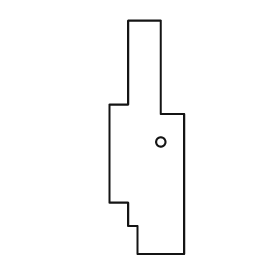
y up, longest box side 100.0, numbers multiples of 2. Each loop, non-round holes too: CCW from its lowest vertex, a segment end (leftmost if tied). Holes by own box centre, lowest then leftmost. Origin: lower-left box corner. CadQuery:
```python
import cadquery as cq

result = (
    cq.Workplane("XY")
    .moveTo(12.0, 0.0)
    .lineTo(32.0, 0.0)
    .lineTo(32.0, 60.0)
    .lineTo(22.0, 60.0)
    .lineTo(22.0, 100.0)
    .lineTo(8.0, 100.0)
    .lineTo(8.0, 64.0)
    .lineTo(0.0, 64.0)
    .lineTo(0.0, 22.0)
    .lineTo(8.0, 22.0)
    .lineTo(8.0, 12.0)
    .lineTo(12.0, 12.0)
    .close()
    .moveTo(22.0, 48.0)
    .circle(2.0)
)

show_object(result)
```